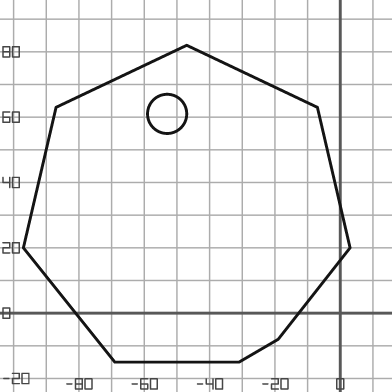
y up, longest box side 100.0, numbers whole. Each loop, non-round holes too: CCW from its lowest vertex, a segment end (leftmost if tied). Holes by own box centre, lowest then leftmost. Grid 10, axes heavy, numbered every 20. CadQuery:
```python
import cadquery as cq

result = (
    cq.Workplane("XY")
    .moveTo(-69.0, -15.0)
    .lineTo(-31.0, -15.0)
    .lineTo(-19.0, -8.0)
    .lineTo(3.0, 20.0)
    .lineTo(-7.0, 63.0)
    .lineTo(-47.0, 82.0)
    .lineTo(-87.0, 63.0)
    .lineTo(-97.0, 20.0)
    .close()
    .moveTo(-53.0, 61.0)
    .circle(6.0)
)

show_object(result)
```